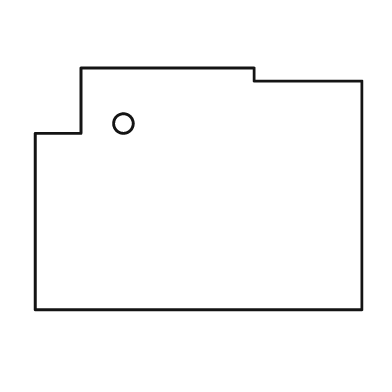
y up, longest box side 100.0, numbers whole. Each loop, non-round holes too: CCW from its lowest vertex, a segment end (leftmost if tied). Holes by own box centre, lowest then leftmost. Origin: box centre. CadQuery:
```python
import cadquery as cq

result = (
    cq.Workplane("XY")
    .moveTo(-50.0, -37.0)
    .lineTo(50.0, -37.0)
    .lineTo(50.0, 33.0)
    .lineTo(17.0, 33.0)
    .lineTo(17.0, 37.0)
    .lineTo(-36.0, 37.0)
    .lineTo(-36.0, 17.0)
    .lineTo(-50.0, 17.0)
    .close()
    .moveTo(-23.0, 20.0)
    .circle(3.0)
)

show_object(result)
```